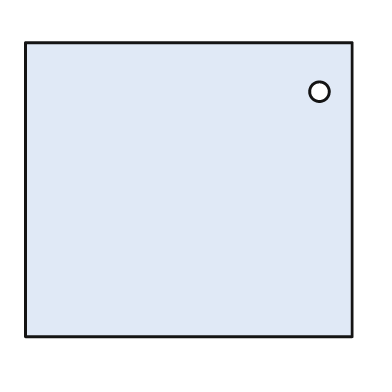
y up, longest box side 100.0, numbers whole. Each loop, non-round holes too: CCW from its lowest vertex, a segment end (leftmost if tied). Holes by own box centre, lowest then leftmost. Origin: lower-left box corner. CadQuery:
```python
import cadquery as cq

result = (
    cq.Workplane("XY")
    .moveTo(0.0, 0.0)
    .lineTo(100.0, 0.0)
    .lineTo(100.0, 90.0)
    .lineTo(0.0, 90.0)
    .close()
    .moveTo(90.0, 75.0)
    .circle(3.0)
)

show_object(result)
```